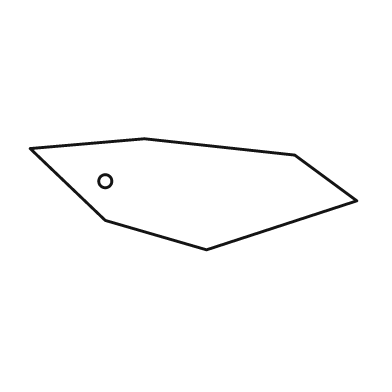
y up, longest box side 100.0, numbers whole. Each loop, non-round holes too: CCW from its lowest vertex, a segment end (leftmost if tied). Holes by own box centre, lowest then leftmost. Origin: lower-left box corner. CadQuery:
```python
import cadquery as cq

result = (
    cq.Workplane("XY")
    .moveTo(54.0, 0.0)
    .lineTo(100.0, 15.0)
    .lineTo(81.0, 29.0)
    .lineTo(35.0, 34.0)
    .lineTo(0.0, 31.0)
    .lineTo(23.0, 9.0)
    .close()
    .moveTo(23.0, 21.0)
    .circle(2.0)
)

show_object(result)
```